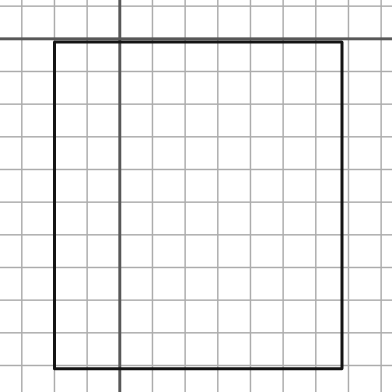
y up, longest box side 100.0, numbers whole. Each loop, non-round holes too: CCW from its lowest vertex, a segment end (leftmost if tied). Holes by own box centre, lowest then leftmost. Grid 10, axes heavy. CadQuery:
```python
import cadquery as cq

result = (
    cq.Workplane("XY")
    .moveTo(-20.0, -101.0)
    .lineTo(68.0, -101.0)
    .lineTo(68.0, -1.0)
    .lineTo(-20.0, -1.0)
    .close()
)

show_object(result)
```